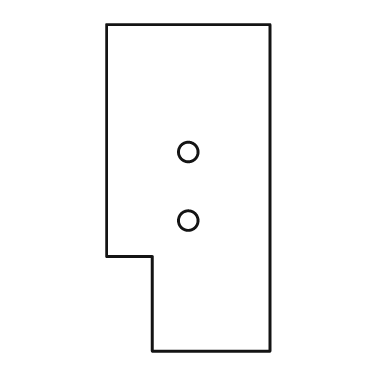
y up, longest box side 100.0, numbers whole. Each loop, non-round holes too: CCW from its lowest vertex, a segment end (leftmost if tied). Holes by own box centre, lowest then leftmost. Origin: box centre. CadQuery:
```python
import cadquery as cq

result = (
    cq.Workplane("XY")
    .moveTo(-11.0, -50.0)
    .lineTo(25.0, -50.0)
    .lineTo(25.0, 50.0)
    .lineTo(-25.0, 50.0)
    .lineTo(-25.0, -21.0)
    .lineTo(-11.0, -21.0)
    .close()
    .moveTo(0.0, -10.0)
    .circle(3.0)
    .moveTo(0.0, 11.0)
    .circle(3.0)
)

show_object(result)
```